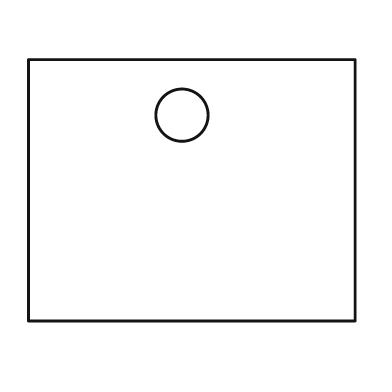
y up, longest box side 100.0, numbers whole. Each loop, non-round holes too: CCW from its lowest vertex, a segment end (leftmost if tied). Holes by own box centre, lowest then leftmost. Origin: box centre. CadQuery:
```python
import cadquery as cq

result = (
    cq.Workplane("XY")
    .moveTo(-50.0, -40.0)
    .lineTo(50.0, -40.0)
    .lineTo(50.0, 40.0)
    .lineTo(-50.0, 40.0)
    .close()
    .moveTo(-3.0, 23.0)
    .circle(8.0)
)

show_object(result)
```